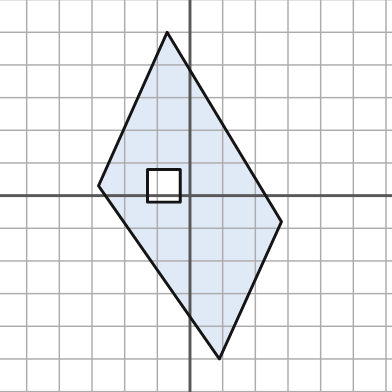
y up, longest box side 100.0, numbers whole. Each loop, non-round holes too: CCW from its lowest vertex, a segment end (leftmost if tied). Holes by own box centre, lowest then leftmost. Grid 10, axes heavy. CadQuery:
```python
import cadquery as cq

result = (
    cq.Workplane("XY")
    .moveTo(9.0, -50.0)
    .lineTo(28.0, -8.0)
    .lineTo(-7.0, 50.0)
    .lineTo(-28.0, 3.0)
    .close()
    .moveTo(-13.0, -2.0)
    .lineTo(-3.0, -2.0)
    .lineTo(-3.0, 8.0)
    .lineTo(-13.0, 8.0)
    .close()
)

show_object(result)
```